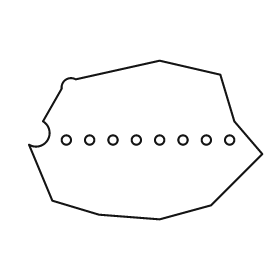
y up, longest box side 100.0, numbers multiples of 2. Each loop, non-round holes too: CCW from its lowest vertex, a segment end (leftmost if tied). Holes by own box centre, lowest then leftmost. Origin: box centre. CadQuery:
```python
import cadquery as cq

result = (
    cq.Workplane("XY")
    .moveTo(6.0, -34.0)
    .lineTo(28.0, -28.0)
    .lineTo(50.0, -6.0)
    .lineTo(38.0, 8.0)
    .lineTo(32.0, 28.0)
    .lineTo(6.0, 34.0)
    .lineTo(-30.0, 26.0)
    .threePointArc((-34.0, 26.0), (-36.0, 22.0))
    .lineTo(-44.0, 8.0)
    .threePointArc((-42.0, 0.0), (-50.0, -2.0))
    .lineTo(-40.0, -26.0)
    .lineTo(-20.0, -32.0)
    .close()
    .moveTo(-34.0, 0.0)
    .circle(2.0)
    .moveTo(-24.0, 0.0)
    .circle(2.0)
    .moveTo(-14.0, 0.0)
    .circle(2.0)
    .moveTo(-4.0, 0.0)
    .circle(2.0)
    .moveTo(6.0, 0.0)
    .circle(2.0)
    .moveTo(16.0, 0.0)
    .circle(2.0)
    .moveTo(26.0, 0.0)
    .circle(2.0)
    .moveTo(36.0, 0.0)
    .circle(2.0)
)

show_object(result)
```